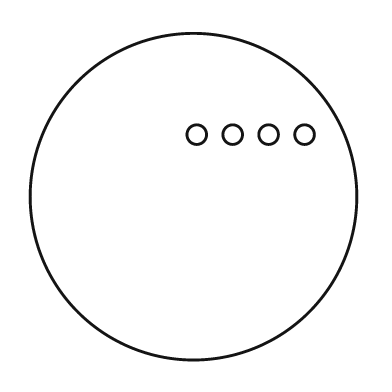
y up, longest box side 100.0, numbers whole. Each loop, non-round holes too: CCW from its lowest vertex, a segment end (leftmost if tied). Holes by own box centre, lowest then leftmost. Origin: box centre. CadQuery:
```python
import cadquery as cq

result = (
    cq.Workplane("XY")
    .moveTo(0.0, 0.0)
    .circle(50.0)
    .moveTo(1.0, 19.0)
    .circle(3.0)
    .moveTo(12.0, 19.0)
    .circle(3.0)
    .moveTo(23.0, 19.0)
    .circle(3.0)
    .moveTo(34.0, 19.0)
    .circle(3.0)
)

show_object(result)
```